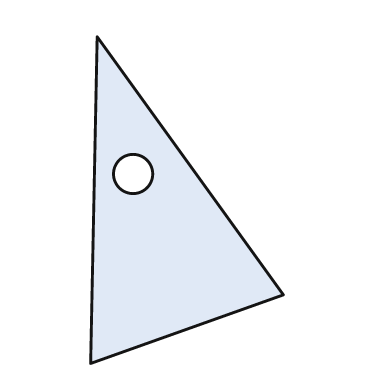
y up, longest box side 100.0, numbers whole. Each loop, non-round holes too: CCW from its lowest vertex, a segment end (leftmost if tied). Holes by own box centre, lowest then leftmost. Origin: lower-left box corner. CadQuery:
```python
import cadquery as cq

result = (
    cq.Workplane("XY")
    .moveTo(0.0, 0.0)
    .lineTo(59.0, 21.0)
    .lineTo(2.0, 100.0)
    .close()
    .moveTo(13.0, 58.0)
    .circle(6.0)
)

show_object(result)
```